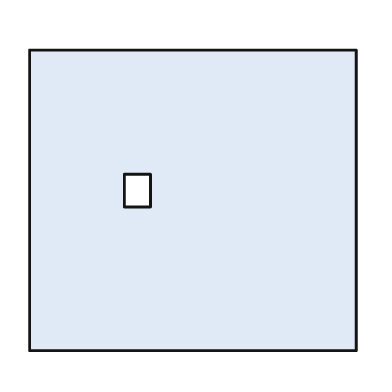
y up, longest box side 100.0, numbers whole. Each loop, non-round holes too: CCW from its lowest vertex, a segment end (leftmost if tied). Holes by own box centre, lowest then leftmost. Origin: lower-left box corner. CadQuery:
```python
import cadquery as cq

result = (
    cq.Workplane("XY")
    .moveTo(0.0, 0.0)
    .lineTo(100.0, 0.0)
    .lineTo(100.0, 92.0)
    .lineTo(0.0, 92.0)
    .close()
    .moveTo(29.0, 44.0)
    .lineTo(37.0, 44.0)
    .lineTo(37.0, 54.0)
    .lineTo(29.0, 54.0)
    .close()
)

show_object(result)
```